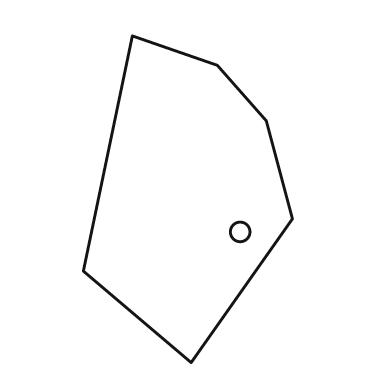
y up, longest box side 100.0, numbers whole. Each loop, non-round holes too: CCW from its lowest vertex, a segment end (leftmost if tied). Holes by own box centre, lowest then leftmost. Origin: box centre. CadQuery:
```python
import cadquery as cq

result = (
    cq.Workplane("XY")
    .moveTo(1.0, -50.0)
    .lineTo(32.0, -6.0)
    .lineTo(24.0, 24.0)
    .lineTo(9.0, 41.0)
    .lineTo(-17.0, 50.0)
    .lineTo(-32.0, -22.0)
    .close()
    .moveTo(16.0, -10.0)
    .circle(3.0)
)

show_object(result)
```